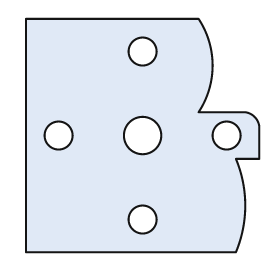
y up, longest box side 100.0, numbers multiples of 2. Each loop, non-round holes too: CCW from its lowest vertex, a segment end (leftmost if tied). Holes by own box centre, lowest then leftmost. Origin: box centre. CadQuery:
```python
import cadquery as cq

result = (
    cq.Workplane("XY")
    .moveTo(-50.0, -50.0)
    .lineTo(40.0, -50.0)
    .threePointArc((44.0, -30.0), (40.0, -10.0))
    .lineTo(50.0, -10.0)
    .lineTo(50.0, 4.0)
    .threePointArc((48.0, 8.0), (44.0, 10.0))
    .lineTo(24.0, 10.0)
    .threePointArc((30.0, 30.0), (24.0, 50.0))
    .lineTo(-50.0, 50.0)
    .close()
    .moveTo(0.0, -36.0)
    .circle(6.0)
    .moveTo(-36.0, 0.0)
    .circle(6.0)
    .moveTo(0.0, 0.0)
    .circle(8.0)
    .moveTo(36.0, 0.0)
    .circle(6.0)
    .moveTo(0.0, 36.0)
    .circle(6.0)
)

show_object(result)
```